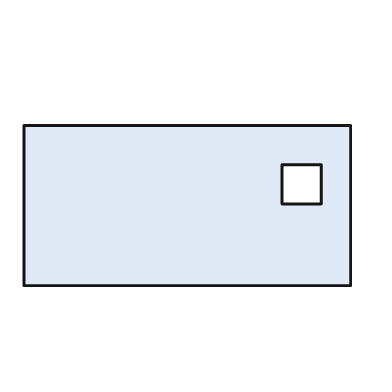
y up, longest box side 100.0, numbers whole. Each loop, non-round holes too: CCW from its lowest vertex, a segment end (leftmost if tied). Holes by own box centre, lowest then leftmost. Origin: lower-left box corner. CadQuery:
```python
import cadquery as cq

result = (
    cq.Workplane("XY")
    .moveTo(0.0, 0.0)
    .lineTo(100.0, 0.0)
    .lineTo(100.0, 49.0)
    .lineTo(0.0, 49.0)
    .close()
    .moveTo(79.0, 25.0)
    .lineTo(91.0, 25.0)
    .lineTo(91.0, 37.0)
    .lineTo(79.0, 37.0)
    .close()
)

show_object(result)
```